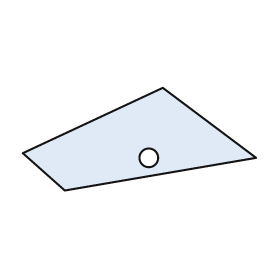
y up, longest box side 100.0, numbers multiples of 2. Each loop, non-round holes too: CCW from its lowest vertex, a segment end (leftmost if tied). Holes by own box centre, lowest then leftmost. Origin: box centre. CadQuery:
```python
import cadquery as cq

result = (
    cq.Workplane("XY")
    .moveTo(-32.0, -22.0)
    .lineTo(50.0, -8.0)
    .lineTo(10.0, 22.0)
    .lineTo(-50.0, -6.0)
    .close()
    .moveTo(4.0, -8.0)
    .circle(4.0)
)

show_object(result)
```